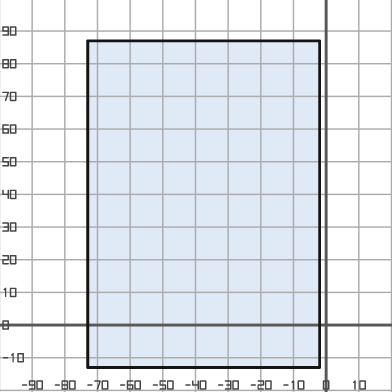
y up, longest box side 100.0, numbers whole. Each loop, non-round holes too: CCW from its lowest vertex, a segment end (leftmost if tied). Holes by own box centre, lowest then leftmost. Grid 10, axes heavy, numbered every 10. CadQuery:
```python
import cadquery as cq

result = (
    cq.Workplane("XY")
    .moveTo(-73.0, -13.0)
    .lineTo(-2.0, -13.0)
    .lineTo(-2.0, 87.0)
    .lineTo(-73.0, 87.0)
    .close()
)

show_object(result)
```